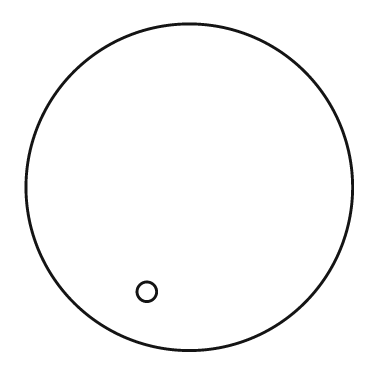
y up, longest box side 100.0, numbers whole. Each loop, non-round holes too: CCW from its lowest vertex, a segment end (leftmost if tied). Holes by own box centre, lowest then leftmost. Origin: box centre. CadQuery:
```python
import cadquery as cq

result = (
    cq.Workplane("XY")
    .moveTo(0.0, 0.0)
    .circle(50.0)
    .moveTo(-13.0, -32.0)
    .circle(3.0)
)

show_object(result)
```